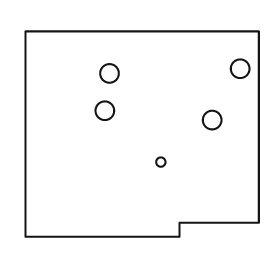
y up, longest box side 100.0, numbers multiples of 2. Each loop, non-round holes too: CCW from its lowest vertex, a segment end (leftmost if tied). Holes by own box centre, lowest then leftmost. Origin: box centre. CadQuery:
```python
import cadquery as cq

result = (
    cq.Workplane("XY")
    .moveTo(-50.0, -44.0)
    .lineTo(16.0, -44.0)
    .lineTo(16.0, -38.0)
    .lineTo(50.0, -38.0)
    .lineTo(50.0, 44.0)
    .lineTo(-50.0, 44.0)
    .close()
    .moveTo(8.0, -12.0)
    .circle(2.0)
    .moveTo(30.0, 6.0)
    .circle(4.0)
    .moveTo(-16.0, 10.0)
    .circle(4.0)
    .moveTo(-14.0, 26.0)
    .circle(4.0)
    .moveTo(42.0, 28.0)
    .circle(4.0)
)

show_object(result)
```